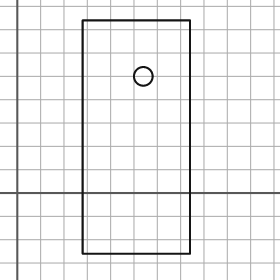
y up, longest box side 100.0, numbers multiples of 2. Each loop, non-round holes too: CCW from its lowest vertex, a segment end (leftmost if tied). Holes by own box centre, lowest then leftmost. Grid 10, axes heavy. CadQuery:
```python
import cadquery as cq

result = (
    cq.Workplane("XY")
    .moveTo(28.0, -26.0)
    .lineTo(74.0, -26.0)
    .lineTo(74.0, 74.0)
    .lineTo(28.0, 74.0)
    .close()
    .moveTo(54.0, 50.0)
    .circle(4.0)
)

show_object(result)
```